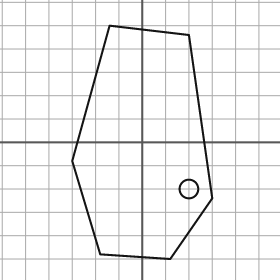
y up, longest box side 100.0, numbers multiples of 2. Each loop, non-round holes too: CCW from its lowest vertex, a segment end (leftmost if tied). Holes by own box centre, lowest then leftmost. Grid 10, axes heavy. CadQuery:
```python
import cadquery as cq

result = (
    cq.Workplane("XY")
    .moveTo(12.0, -50.0)
    .lineTo(30.0, -24.0)
    .lineTo(20.0, 46.0)
    .lineTo(-14.0, 50.0)
    .lineTo(-30.0, -8.0)
    .lineTo(-18.0, -48.0)
    .close()
    .moveTo(20.0, -20.0)
    .circle(4.0)
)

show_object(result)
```